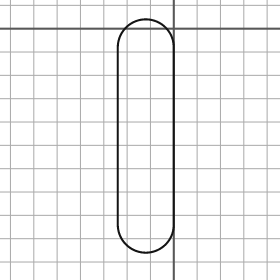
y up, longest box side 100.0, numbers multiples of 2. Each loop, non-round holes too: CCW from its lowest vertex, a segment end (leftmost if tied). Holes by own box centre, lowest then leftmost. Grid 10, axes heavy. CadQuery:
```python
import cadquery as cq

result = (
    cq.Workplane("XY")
    .moveTo(-24.0, -84.0)
    .threePointArc((-12.0, -96.0), (0.0, -84.0))
    .lineTo(0.0, -8.0)
    .threePointArc((-12.0, 4.0), (-24.0, -8.0))
    .close()
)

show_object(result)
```